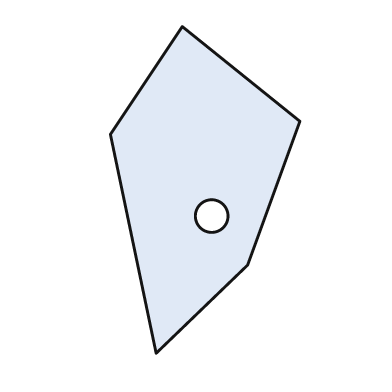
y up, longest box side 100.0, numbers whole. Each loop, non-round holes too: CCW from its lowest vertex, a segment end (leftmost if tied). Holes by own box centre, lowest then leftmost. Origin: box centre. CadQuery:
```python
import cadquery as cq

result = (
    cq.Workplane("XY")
    .moveTo(-15.0, -50.0)
    .lineTo(13.0, -23.0)
    .lineTo(29.0, 21.0)
    .lineTo(-7.0, 50.0)
    .lineTo(-29.0, 17.0)
    .close()
    .moveTo(2.0, -8.0)
    .circle(5.0)
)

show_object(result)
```